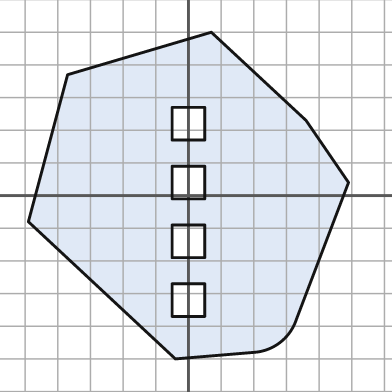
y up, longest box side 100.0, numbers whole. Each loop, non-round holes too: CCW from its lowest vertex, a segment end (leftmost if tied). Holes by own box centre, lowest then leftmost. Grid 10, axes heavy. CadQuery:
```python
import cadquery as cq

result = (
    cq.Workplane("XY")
    .moveTo(-4.0, -50.0)
    .lineTo(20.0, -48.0)
    .threePointArc((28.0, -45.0), (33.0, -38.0))
    .lineTo(49.0, 4.0)
    .lineTo(36.0, 23.0)
    .lineTo(7.0, 50.0)
    .lineTo(-37.0, 37.0)
    .lineTo(-49.0, -8.0)
    .close()
    .moveTo(-5.0, -37.0)
    .lineTo(5.0, -37.0)
    .lineTo(5.0, -27.0)
    .lineTo(-5.0, -27.0)
    .close()
    .moveTo(-5.0, -19.0)
    .lineTo(5.0, -19.0)
    .lineTo(5.0, -9.0)
    .lineTo(-5.0, -9.0)
    .close()
    .moveTo(-5.0, -1.0)
    .lineTo(5.0, -1.0)
    .lineTo(5.0, 9.0)
    .lineTo(-5.0, 9.0)
    .close()
    .moveTo(-5.0, 17.0)
    .lineTo(5.0, 17.0)
    .lineTo(5.0, 27.0)
    .lineTo(-5.0, 27.0)
    .close()
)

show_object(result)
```